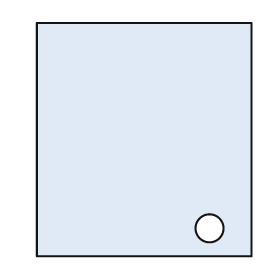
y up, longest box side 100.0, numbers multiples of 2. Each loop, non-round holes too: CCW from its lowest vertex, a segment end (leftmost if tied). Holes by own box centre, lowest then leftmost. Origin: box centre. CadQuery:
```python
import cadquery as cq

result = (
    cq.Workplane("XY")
    .moveTo(-46.0, -50.0)
    .lineTo(46.0, -50.0)
    .lineTo(46.0, 50.0)
    .lineTo(-46.0, 50.0)
    .close()
    .moveTo(28.0, -38.0)
    .circle(6.0)
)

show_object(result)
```